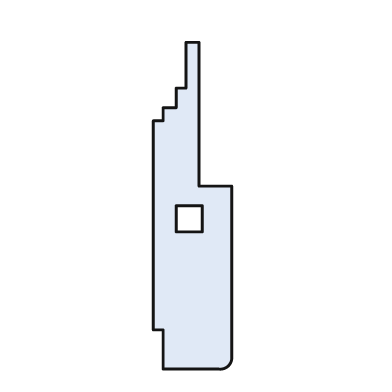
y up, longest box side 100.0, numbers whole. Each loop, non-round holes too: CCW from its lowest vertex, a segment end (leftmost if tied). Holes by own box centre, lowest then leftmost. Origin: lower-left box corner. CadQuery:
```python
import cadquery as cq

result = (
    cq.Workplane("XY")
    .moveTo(3.0, 0.0)
    .lineTo(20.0, 0.0)
    .threePointArc((23.0, 1.0), (24.0, 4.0))
    .lineTo(24.0, 56.0)
    .lineTo(14.0, 56.0)
    .lineTo(14.0, 100.0)
    .lineTo(10.0, 100.0)
    .lineTo(10.0, 86.0)
    .lineTo(7.0, 86.0)
    .lineTo(7.0, 80.0)
    .lineTo(3.0, 80.0)
    .lineTo(3.0, 76.0)
    .lineTo(0.0, 76.0)
    .lineTo(0.0, 12.0)
    .lineTo(3.0, 12.0)
    .close()
    .moveTo(7.0, 42.0)
    .lineTo(15.0, 42.0)
    .lineTo(15.0, 50.0)
    .lineTo(7.0, 50.0)
    .close()
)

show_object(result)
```